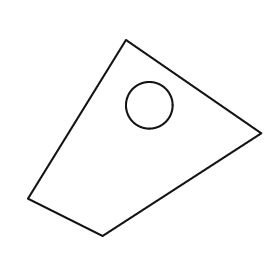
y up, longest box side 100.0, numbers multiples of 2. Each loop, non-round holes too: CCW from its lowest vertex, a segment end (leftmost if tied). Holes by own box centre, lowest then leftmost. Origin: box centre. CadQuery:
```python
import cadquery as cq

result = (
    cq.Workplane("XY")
    .moveTo(-18.0, -42.0)
    .lineTo(50.0, 2.0)
    .lineTo(-8.0, 42.0)
    .lineTo(-50.0, -26.0)
    .close()
    .moveTo(2.0, 14.0)
    .circle(10.0)
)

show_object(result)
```